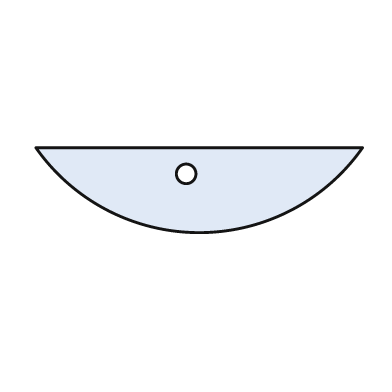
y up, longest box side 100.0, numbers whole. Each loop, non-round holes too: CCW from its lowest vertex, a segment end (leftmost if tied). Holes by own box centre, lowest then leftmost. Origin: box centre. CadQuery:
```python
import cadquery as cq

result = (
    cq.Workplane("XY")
    .moveTo(-50.0, 13.0)
    .threePointArc((0.0, -13.0), (50.0, 13.0))
    .close()
    .moveTo(-4.0, 5.0)
    .circle(3.0)
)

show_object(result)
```